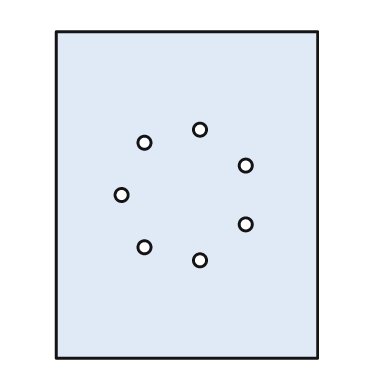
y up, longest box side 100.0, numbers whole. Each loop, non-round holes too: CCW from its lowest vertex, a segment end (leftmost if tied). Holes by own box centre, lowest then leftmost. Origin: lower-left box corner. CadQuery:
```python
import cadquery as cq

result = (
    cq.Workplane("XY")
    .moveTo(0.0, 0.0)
    .lineTo(80.0, 0.0)
    .lineTo(80.0, 100.0)
    .lineTo(0.0, 100.0)
    .close()
    .moveTo(44.0, 30.0)
    .circle(2.0)
    .moveTo(27.0, 34.0)
    .circle(2.0)
    .moveTo(58.0, 41.0)
    .circle(2.0)
    .moveTo(20.0, 50.0)
    .circle(2.0)
    .moveTo(58.0, 59.0)
    .circle(2.0)
    .moveTo(27.0, 66.0)
    .circle(2.0)
    .moveTo(44.0, 70.0)
    .circle(2.0)
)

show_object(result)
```